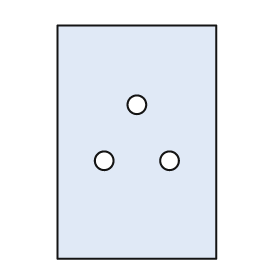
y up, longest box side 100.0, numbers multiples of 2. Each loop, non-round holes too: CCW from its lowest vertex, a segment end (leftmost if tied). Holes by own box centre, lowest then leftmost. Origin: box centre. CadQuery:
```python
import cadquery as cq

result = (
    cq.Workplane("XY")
    .moveTo(-34.0, -50.0)
    .lineTo(34.0, -50.0)
    .lineTo(34.0, 50.0)
    .lineTo(-34.0, 50.0)
    .close()
    .moveTo(-14.0, -8.0)
    .circle(4.0)
    .moveTo(14.0, -8.0)
    .circle(4.0)
    .moveTo(0.0, 16.0)
    .circle(4.0)
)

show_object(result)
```